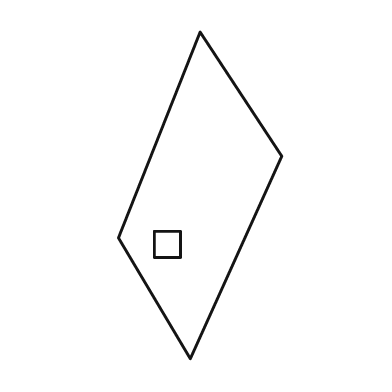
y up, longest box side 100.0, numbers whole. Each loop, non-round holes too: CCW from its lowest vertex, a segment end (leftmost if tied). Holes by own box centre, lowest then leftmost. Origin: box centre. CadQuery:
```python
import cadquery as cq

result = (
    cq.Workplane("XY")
    .moveTo(-3.0, -50.0)
    .lineTo(25.0, 12.0)
    .lineTo(0.0, 50.0)
    .lineTo(-25.0, -13.0)
    .close()
    .moveTo(-14.0, -19.0)
    .lineTo(-6.0, -19.0)
    .lineTo(-6.0, -11.0)
    .lineTo(-14.0, -11.0)
    .close()
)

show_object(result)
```